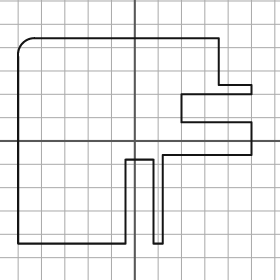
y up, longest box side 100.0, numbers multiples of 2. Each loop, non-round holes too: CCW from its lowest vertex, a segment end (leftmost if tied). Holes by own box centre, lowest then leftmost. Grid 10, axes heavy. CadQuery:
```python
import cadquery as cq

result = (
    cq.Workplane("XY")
    .moveTo(-50.0, -44.0)
    .lineTo(-4.0, -44.0)
    .lineTo(-4.0, -8.0)
    .lineTo(8.0, -8.0)
    .lineTo(8.0, -44.0)
    .lineTo(12.0, -44.0)
    .lineTo(12.0, -6.0)
    .lineTo(50.0, -6.0)
    .lineTo(50.0, 8.0)
    .lineTo(20.0, 8.0)
    .lineTo(20.0, 20.0)
    .lineTo(50.0, 20.0)
    .lineTo(50.0, 24.0)
    .lineTo(36.0, 24.0)
    .lineTo(36.0, 44.0)
    .lineTo(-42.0, 44.0)
    .threePointArc((-48.0, 42.0), (-50.0, 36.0))
    .close()
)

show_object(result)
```